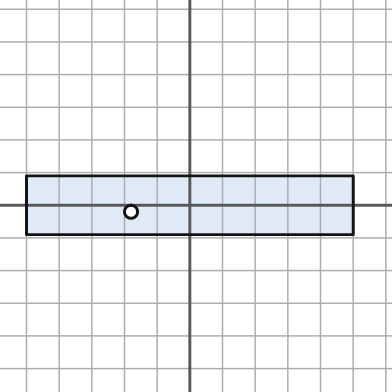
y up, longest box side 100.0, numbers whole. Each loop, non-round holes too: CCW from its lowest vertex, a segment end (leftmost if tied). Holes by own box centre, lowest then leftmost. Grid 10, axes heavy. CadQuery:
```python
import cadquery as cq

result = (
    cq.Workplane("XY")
    .moveTo(-50.0, -9.0)
    .lineTo(50.0, -9.0)
    .lineTo(50.0, 9.0)
    .lineTo(-50.0, 9.0)
    .close()
    .moveTo(-18.0, -2.0)
    .circle(2.0)
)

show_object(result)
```